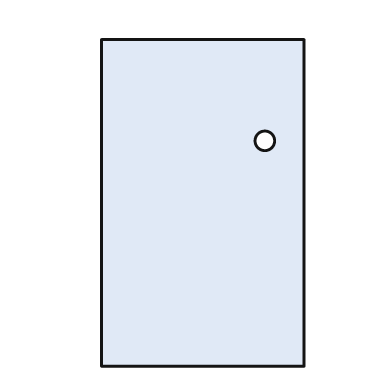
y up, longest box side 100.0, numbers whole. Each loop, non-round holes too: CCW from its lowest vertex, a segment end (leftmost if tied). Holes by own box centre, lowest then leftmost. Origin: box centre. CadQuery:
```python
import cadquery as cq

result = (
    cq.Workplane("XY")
    .moveTo(-31.0, -50.0)
    .lineTo(31.0, -50.0)
    .lineTo(31.0, 50.0)
    .lineTo(-31.0, 50.0)
    .close()
    .moveTo(19.0, 19.0)
    .circle(3.0)
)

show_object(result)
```